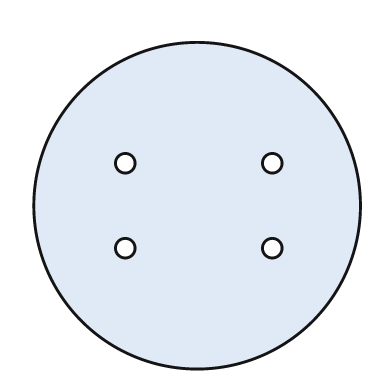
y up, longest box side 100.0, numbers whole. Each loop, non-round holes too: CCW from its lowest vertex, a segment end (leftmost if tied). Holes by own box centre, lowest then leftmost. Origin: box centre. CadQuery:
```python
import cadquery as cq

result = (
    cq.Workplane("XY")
    .moveTo(0.0, 0.0)
    .circle(50.0)
    .moveTo(-22.0, -13.0)
    .circle(3.0)
    .moveTo(23.0, -13.0)
    .circle(3.0)
    .moveTo(-22.0, 13.0)
    .circle(3.0)
    .moveTo(23.0, 13.0)
    .circle(3.0)
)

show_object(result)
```